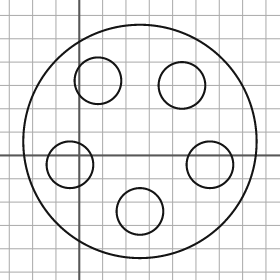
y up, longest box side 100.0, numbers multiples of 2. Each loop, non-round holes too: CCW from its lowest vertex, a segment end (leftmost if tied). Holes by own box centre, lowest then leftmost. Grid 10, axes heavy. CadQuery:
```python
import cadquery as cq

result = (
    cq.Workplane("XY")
    .moveTo(26.0, 6.0)
    .circle(50.0)
    .moveTo(26.0, -24.0)
    .circle(10.0)
    .moveTo(-4.0, -4.0)
    .circle(10.0)
    .moveTo(56.0, -4.0)
    .circle(10.0)
    .moveTo(44.0, 30.0)
    .circle(10.0)
    .moveTo(8.0, 32.0)
    .circle(10.0)
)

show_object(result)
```